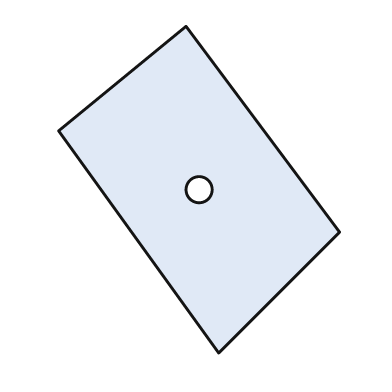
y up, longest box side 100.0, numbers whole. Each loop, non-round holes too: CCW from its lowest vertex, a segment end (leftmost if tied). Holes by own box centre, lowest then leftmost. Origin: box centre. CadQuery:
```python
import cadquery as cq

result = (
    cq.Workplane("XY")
    .moveTo(6.0, -50.0)
    .lineTo(43.0, -13.0)
    .lineTo(-4.0, 50.0)
    .lineTo(-43.0, 18.0)
    .close()
    .moveTo(0.0, 0.0)
    .circle(4.0)
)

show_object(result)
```